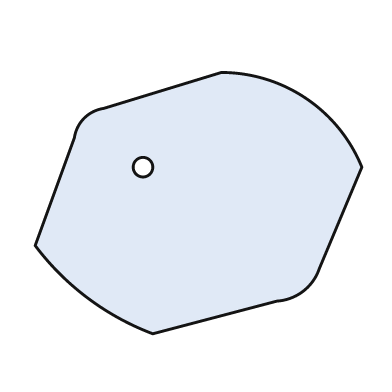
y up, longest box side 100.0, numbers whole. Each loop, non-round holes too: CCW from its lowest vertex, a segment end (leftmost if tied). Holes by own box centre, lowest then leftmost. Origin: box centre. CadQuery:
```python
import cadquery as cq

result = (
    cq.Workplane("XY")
    .moveTo(-14.0, -40.0)
    .lineTo(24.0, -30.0)
    .threePointArc((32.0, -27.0), (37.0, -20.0))
    .lineTo(50.0, 11.0)
    .threePointArc((33.0, 32.0), (7.0, 40.0))
    .lineTo(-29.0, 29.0)
    .threePointArc((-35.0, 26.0), (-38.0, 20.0))
    .lineTo(-50.0, -13.0)
    .threePointArc((-34.0, -29.0), (-14.0, -40.0))
    .close()
    .moveTo(-17.0, 11.0)
    .circle(3.0)
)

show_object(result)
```